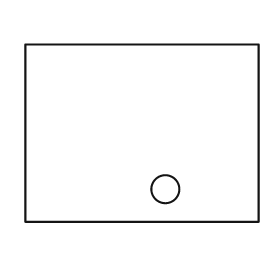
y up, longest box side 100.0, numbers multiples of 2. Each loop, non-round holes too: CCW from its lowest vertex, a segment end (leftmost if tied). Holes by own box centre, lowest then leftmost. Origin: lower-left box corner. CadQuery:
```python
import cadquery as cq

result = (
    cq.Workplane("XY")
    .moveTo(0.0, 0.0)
    .lineTo(100.0, 0.0)
    .lineTo(100.0, 76.0)
    .lineTo(0.0, 76.0)
    .close()
    .moveTo(60.0, 14.0)
    .circle(6.0)
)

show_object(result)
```